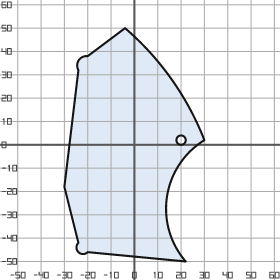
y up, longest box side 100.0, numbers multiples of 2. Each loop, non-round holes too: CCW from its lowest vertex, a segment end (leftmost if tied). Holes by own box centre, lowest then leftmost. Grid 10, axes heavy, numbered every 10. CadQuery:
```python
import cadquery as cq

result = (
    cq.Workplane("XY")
    .moveTo(22.0, -50.0)
    .threePointArc((14.0, -22.0), (30.0, 2.0))
    .threePointArc((16.0, 28.0), (-4.0, 50.0))
    .lineTo(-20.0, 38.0)
    .threePointArc((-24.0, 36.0), (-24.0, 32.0))
    .lineTo(-30.0, -18.0)
    .lineTo(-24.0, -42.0)
    .threePointArc((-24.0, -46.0), (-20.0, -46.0))
    .close()
    .moveTo(20.0, 2.0)
    .circle(2.0)
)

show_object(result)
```